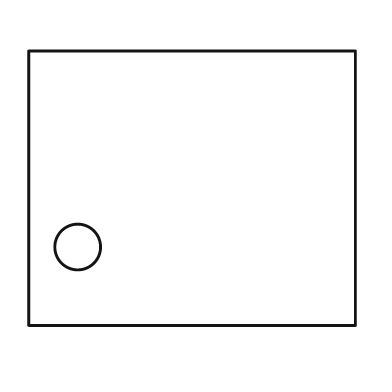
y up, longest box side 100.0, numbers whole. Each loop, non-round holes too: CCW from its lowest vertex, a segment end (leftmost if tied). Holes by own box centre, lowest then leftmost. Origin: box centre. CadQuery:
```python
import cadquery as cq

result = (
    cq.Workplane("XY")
    .moveTo(-50.0, -42.0)
    .lineTo(50.0, -42.0)
    .lineTo(50.0, 42.0)
    .lineTo(-50.0, 42.0)
    .close()
    .moveTo(-35.0, -18.0)
    .circle(7.0)
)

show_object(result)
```